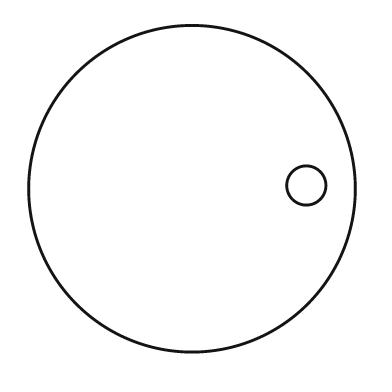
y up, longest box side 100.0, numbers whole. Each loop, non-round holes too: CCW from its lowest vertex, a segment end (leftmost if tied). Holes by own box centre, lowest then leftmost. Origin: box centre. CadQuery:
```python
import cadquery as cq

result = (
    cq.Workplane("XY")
    .moveTo(0.0, 0.0)
    .circle(50.0)
    .moveTo(35.0, 1.0)
    .circle(6.0)
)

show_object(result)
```